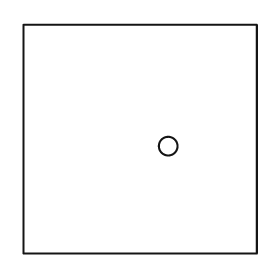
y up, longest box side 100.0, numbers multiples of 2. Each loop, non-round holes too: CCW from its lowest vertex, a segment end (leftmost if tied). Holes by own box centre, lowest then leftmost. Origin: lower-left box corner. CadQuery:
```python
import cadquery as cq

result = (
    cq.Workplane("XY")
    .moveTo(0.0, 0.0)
    .lineTo(100.0, 0.0)
    .lineTo(100.0, 98.0)
    .lineTo(0.0, 98.0)
    .close()
    .moveTo(62.0, 46.0)
    .circle(4.0)
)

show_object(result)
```